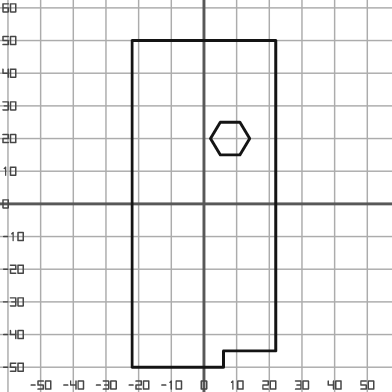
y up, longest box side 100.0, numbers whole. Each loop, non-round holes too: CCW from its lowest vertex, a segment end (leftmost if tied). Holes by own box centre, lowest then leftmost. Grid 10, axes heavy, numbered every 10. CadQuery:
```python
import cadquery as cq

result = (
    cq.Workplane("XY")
    .moveTo(-22.0, -50.0)
    .lineTo(6.0, -50.0)
    .lineTo(6.0, -45.0)
    .lineTo(22.0, -45.0)
    .lineTo(22.0, 50.0)
    .lineTo(-22.0, 50.0)
    .close()
    .moveTo(5.0, 15.0)
    .lineTo(11.0, 15.0)
    .lineTo(14.0, 20.0)
    .lineTo(11.0, 25.0)
    .lineTo(5.0, 25.0)
    .lineTo(2.0, 20.0)
    .close()
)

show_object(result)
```